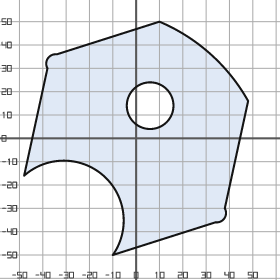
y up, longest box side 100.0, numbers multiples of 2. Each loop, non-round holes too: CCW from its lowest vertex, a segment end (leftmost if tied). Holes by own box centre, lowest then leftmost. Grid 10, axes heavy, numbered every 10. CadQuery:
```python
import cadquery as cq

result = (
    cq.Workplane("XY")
    .moveTo(-10.0, -50.0)
    .lineTo(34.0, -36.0)
    .threePointArc((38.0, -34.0), (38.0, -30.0))
    .lineTo(48.0, 16.0)
    .threePointArc((32.0, 36.0), (10.0, 50.0))
    .lineTo(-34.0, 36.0)
    .threePointArc((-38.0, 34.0), (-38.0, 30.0))
    .lineTo(-48.0, -16.0)
    .threePointArc((-14.0, -16.0), (-10.0, -50.0))
    .close()
    .moveTo(6.0, 14.0)
    .circle(10.0)
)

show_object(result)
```